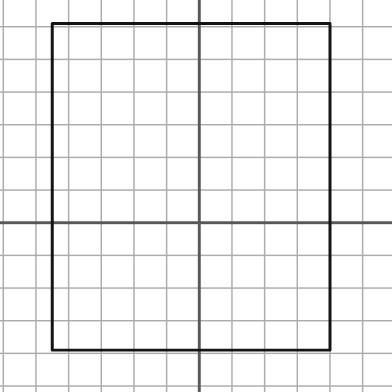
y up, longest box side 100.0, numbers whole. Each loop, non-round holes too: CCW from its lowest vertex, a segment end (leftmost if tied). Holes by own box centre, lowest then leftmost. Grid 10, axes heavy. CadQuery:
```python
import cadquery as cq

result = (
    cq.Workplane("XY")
    .moveTo(-45.0, -39.0)
    .lineTo(40.0, -39.0)
    .lineTo(40.0, 61.0)
    .lineTo(-45.0, 61.0)
    .close()
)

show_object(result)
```